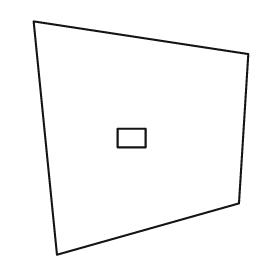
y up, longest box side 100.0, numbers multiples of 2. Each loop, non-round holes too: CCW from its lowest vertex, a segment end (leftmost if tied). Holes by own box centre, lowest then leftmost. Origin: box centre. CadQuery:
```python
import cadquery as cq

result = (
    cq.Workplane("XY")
    .moveTo(-36.0, -50.0)
    .lineTo(42.0, -28.0)
    .lineTo(46.0, 36.0)
    .lineTo(-46.0, 50.0)
    .close()
    .moveTo(-10.0, -4.0)
    .lineTo(2.0, -4.0)
    .lineTo(2.0, 4.0)
    .lineTo(-10.0, 4.0)
    .close()
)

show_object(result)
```